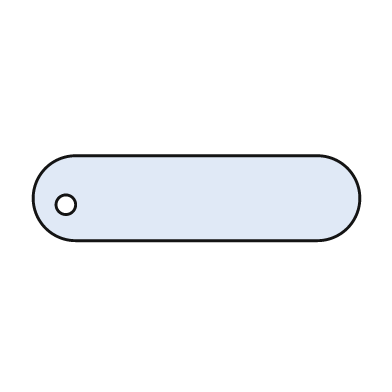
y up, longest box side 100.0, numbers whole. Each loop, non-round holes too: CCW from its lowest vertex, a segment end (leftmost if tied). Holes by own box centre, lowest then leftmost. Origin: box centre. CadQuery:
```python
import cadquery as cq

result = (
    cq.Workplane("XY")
    .moveTo(-37.0, -13.0)
    .lineTo(37.0, -13.0)
    .threePointArc((50.0, 0.0), (37.0, 13.0))
    .lineTo(-37.0, 13.0)
    .threePointArc((-50.0, 0.0), (-37.0, -13.0))
    .close()
    .moveTo(-40.0, -2.0)
    .circle(3.0)
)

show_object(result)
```